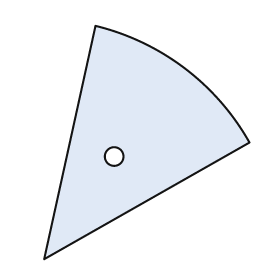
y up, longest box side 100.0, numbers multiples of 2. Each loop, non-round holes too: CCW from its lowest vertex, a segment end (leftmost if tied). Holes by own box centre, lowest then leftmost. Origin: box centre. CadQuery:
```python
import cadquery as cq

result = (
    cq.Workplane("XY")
    .moveTo(-44.0, -50.0)
    .lineTo(44.0, 0.0)
    .threePointArc((16.0, 32.0), (-22.0, 50.0))
    .close()
    .moveTo(-14.0, -6.0)
    .circle(4.0)
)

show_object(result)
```